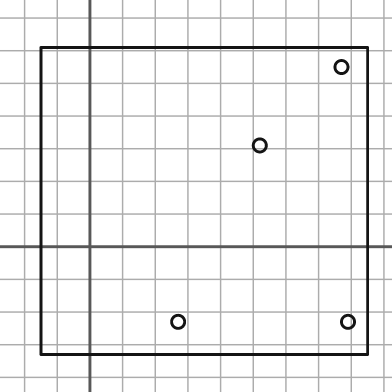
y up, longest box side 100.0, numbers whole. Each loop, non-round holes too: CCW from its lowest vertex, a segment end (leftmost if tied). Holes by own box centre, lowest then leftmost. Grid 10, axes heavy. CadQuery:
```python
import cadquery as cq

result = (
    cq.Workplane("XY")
    .moveTo(-15.0, -33.0)
    .lineTo(85.0, -33.0)
    .lineTo(85.0, 61.0)
    .lineTo(-15.0, 61.0)
    .close()
    .moveTo(27.0, -23.0)
    .circle(2.0)
    .moveTo(79.0, -23.0)
    .circle(2.0)
    .moveTo(52.0, 31.0)
    .circle(2.0)
    .moveTo(77.0, 55.0)
    .circle(2.0)
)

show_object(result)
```